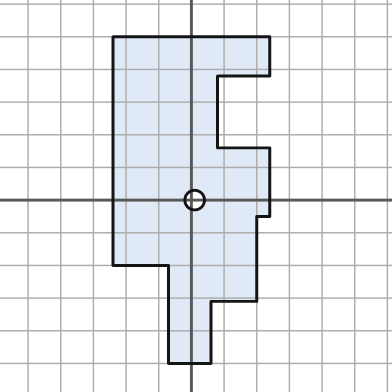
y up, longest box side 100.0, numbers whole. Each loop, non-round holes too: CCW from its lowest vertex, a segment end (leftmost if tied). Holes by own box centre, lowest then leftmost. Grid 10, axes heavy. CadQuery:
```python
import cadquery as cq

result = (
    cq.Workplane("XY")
    .moveTo(-7.0, -50.0)
    .lineTo(6.0, -50.0)
    .lineTo(6.0, -31.0)
    .lineTo(20.0, -31.0)
    .lineTo(20.0, -5.0)
    .lineTo(24.0, -5.0)
    .lineTo(24.0, 16.0)
    .lineTo(8.0, 16.0)
    .lineTo(8.0, 38.0)
    .lineTo(24.0, 38.0)
    .lineTo(24.0, 50.0)
    .lineTo(-24.0, 50.0)
    .lineTo(-24.0, -20.0)
    .lineTo(-7.0, -20.0)
    .close()
    .moveTo(1.0, 0.0)
    .circle(3.0)
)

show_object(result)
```